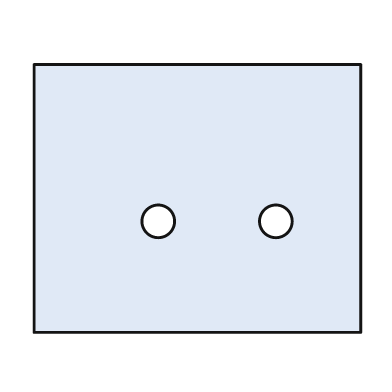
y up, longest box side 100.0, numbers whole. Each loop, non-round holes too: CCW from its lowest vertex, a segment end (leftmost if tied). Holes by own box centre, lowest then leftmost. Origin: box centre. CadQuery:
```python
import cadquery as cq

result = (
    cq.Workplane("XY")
    .moveTo(-50.0, -41.0)
    .lineTo(50.0, -41.0)
    .lineTo(50.0, 41.0)
    .lineTo(-50.0, 41.0)
    .close()
    .moveTo(-12.0, -7.0)
    .circle(5.0)
    .moveTo(24.0, -7.0)
    .circle(5.0)
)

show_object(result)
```